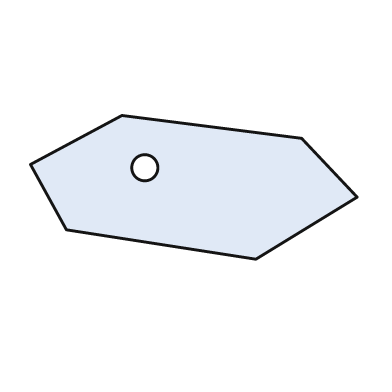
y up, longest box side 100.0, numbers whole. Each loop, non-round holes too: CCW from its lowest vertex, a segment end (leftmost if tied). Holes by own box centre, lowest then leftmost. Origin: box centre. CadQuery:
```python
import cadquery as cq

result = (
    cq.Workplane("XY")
    .moveTo(19.0, -22.0)
    .lineTo(50.0, -3.0)
    .lineTo(33.0, 15.0)
    .lineTo(-22.0, 22.0)
    .lineTo(-50.0, 7.0)
    .lineTo(-39.0, -13.0)
    .close()
    .moveTo(-15.0, 6.0)
    .circle(4.0)
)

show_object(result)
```